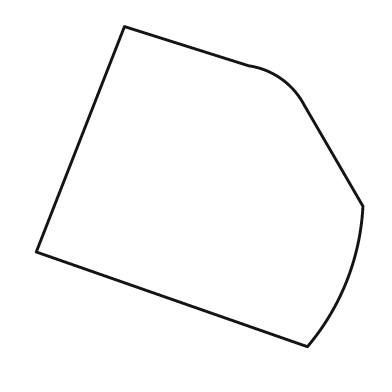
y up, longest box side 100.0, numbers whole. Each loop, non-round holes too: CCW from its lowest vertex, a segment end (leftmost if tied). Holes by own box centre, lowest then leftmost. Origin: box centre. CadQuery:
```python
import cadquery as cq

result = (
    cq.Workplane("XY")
    .moveTo(33.0, -49.0)
    .threePointArc((45.0, -29.0), (50.0, -6.0))
    .lineTo(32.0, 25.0)
    .threePointArc((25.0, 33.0), (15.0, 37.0))
    .lineTo(-23.0, 49.0)
    .lineTo(-50.0, -20.0)
    .close()
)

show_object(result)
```